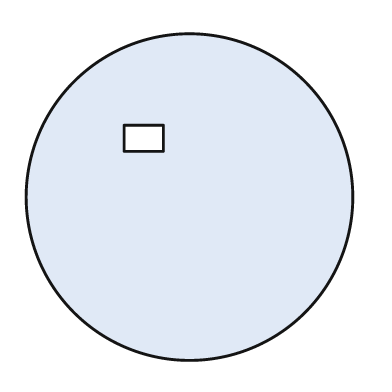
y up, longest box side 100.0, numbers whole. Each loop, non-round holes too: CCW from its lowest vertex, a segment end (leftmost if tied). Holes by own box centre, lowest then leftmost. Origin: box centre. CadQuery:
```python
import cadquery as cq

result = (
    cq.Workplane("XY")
    .moveTo(0.0, 0.0)
    .circle(50.0)
    .moveTo(-20.0, 14.0)
    .lineTo(-8.0, 14.0)
    .lineTo(-8.0, 22.0)
    .lineTo(-20.0, 22.0)
    .close()
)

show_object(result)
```